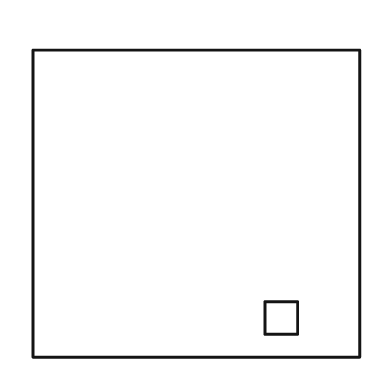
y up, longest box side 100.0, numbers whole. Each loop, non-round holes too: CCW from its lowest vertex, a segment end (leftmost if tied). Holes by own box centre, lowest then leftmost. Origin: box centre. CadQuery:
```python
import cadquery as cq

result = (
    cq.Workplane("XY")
    .moveTo(-50.0, -47.0)
    .lineTo(50.0, -47.0)
    .lineTo(50.0, 47.0)
    .lineTo(-50.0, 47.0)
    .close()
    .moveTo(21.0, -40.0)
    .lineTo(31.0, -40.0)
    .lineTo(31.0, -30.0)
    .lineTo(21.0, -30.0)
    .close()
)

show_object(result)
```